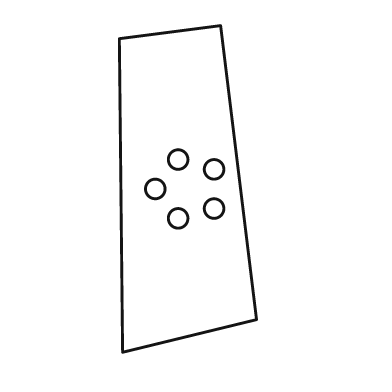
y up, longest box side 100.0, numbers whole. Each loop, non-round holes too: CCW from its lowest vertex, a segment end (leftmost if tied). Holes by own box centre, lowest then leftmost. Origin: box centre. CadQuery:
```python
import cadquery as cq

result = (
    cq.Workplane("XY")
    .moveTo(-20.0, -50.0)
    .lineTo(21.0, -40.0)
    .lineTo(10.0, 50.0)
    .lineTo(-21.0, 46.0)
    .close()
    .moveTo(-3.0, -9.0)
    .circle(3.0)
    .moveTo(8.0, -6.0)
    .circle(3.0)
    .moveTo(-10.0, 0.0)
    .circle(3.0)
    .moveTo(8.0, 6.0)
    .circle(3.0)
    .moveTo(-3.0, 9.0)
    .circle(3.0)
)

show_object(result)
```